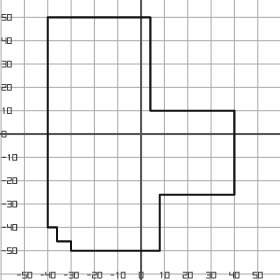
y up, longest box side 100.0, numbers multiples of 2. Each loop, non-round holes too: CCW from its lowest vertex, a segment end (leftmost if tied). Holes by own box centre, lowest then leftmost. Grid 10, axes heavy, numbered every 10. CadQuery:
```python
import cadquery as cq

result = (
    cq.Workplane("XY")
    .moveTo(-30.0, -50.0)
    .lineTo(8.0, -50.0)
    .lineTo(8.0, -26.0)
    .lineTo(40.0, -26.0)
    .lineTo(40.0, 10.0)
    .lineTo(4.0, 10.0)
    .lineTo(4.0, 50.0)
    .lineTo(-40.0, 50.0)
    .lineTo(-40.0, -40.0)
    .lineTo(-36.0, -40.0)
    .lineTo(-36.0, -46.0)
    .lineTo(-30.0, -46.0)
    .close()
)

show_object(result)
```